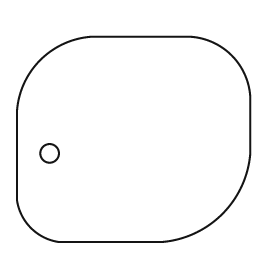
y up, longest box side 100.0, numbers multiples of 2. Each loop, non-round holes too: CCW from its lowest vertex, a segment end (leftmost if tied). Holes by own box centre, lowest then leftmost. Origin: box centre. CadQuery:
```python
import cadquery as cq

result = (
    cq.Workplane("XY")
    .moveTo(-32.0, -44.0)
    .lineTo(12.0, -44.0)
    .threePointArc((38.0, -32.0), (50.0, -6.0))
    .lineTo(50.0, 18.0)
    .threePointArc((42.0, 36.0), (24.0, 44.0))
    .lineTo(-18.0, 44.0)
    .threePointArc((-40.0, 34.0), (-50.0, 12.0))
    .lineTo(-50.0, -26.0)
    .threePointArc((-44.0, -38.0), (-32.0, -44.0))
    .close()
    .moveTo(-36.0, -6.0)
    .circle(4.0)
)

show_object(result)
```